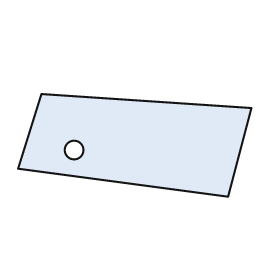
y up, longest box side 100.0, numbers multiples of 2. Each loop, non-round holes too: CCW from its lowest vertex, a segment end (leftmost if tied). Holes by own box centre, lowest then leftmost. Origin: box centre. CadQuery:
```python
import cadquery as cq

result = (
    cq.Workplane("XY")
    .moveTo(40.0, -22.0)
    .lineTo(50.0, 16.0)
    .lineTo(-40.0, 22.0)
    .lineTo(-50.0, -10.0)
    .close()
    .moveTo(-26.0, -2.0)
    .circle(4.0)
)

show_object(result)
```